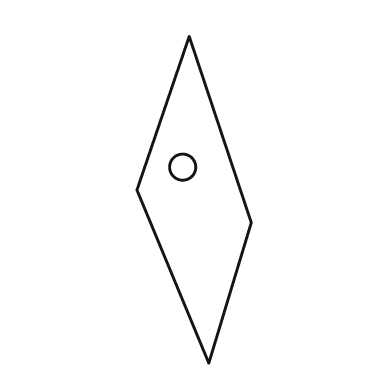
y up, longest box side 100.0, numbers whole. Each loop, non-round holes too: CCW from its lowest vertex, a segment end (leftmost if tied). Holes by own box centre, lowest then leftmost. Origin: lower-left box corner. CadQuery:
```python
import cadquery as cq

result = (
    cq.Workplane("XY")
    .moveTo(22.0, 0.0)
    .lineTo(35.0, 43.0)
    .lineTo(16.0, 100.0)
    .lineTo(0.0, 53.0)
    .close()
    .moveTo(14.0, 60.0)
    .circle(4.0)
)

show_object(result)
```